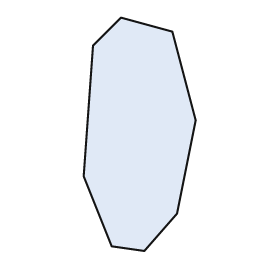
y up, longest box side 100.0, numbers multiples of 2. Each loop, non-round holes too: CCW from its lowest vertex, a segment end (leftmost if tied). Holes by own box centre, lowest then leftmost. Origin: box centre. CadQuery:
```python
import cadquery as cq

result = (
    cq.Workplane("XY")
    .moveTo(2.0, -50.0)
    .lineTo(16.0, -34.0)
    .lineTo(24.0, 6.0)
    .lineTo(14.0, 44.0)
    .lineTo(-8.0, 50.0)
    .lineTo(-20.0, 38.0)
    .lineTo(-24.0, -18.0)
    .lineTo(-12.0, -48.0)
    .close()
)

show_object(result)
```